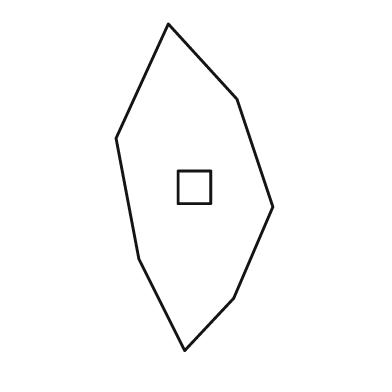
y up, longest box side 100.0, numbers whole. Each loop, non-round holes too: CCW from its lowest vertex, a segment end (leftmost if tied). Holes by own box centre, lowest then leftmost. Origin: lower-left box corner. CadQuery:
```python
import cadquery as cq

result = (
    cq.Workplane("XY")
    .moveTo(21.0, 0.0)
    .lineTo(36.0, 16.0)
    .lineTo(48.0, 44.0)
    .lineTo(37.0, 77.0)
    .lineTo(16.0, 100.0)
    .lineTo(0.0, 65.0)
    .lineTo(7.0, 28.0)
    .close()
    .moveTo(19.0, 45.0)
    .lineTo(29.0, 45.0)
    .lineTo(29.0, 55.0)
    .lineTo(19.0, 55.0)
    .close()
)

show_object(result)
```